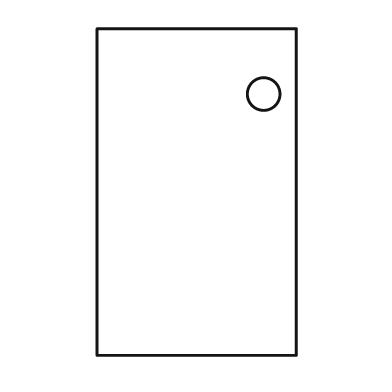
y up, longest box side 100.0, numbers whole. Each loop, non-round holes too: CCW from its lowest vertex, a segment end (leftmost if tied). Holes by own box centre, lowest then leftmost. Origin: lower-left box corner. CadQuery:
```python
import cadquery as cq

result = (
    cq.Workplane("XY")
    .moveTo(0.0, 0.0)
    .lineTo(61.0, 0.0)
    .lineTo(61.0, 100.0)
    .lineTo(0.0, 100.0)
    .close()
    .moveTo(51.0, 80.0)
    .circle(5.0)
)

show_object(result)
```